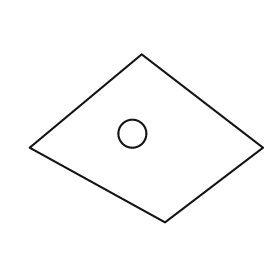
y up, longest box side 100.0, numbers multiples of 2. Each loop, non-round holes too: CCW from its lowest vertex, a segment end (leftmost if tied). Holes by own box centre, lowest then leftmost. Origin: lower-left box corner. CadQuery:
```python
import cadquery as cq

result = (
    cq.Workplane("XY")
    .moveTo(58.0, 0.0)
    .lineTo(100.0, 32.0)
    .lineTo(48.0, 72.0)
    .lineTo(0.0, 32.0)
    .close()
    .moveTo(44.0, 38.0)
    .circle(6.0)
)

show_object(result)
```